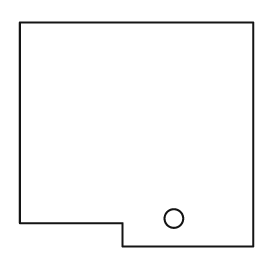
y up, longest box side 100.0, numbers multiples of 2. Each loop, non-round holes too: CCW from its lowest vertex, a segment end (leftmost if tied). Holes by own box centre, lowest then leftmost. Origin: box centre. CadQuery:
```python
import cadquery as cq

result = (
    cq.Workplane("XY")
    .moveTo(-6.0, -48.0)
    .lineTo(50.0, -48.0)
    .lineTo(50.0, 48.0)
    .lineTo(-50.0, 48.0)
    .lineTo(-50.0, -38.0)
    .lineTo(-6.0, -38.0)
    .close()
    .moveTo(16.0, -36.0)
    .circle(4.0)
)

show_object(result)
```